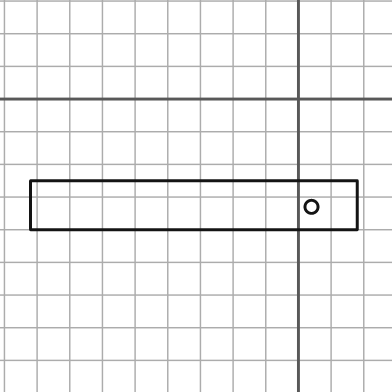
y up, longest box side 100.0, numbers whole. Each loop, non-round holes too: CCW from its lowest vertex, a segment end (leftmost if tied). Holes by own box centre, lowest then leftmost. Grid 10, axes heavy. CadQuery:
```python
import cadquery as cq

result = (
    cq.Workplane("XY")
    .moveTo(-82.0, -40.0)
    .lineTo(18.0, -40.0)
    .lineTo(18.0, -25.0)
    .lineTo(-82.0, -25.0)
    .close()
    .moveTo(4.0, -33.0)
    .circle(2.0)
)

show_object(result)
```